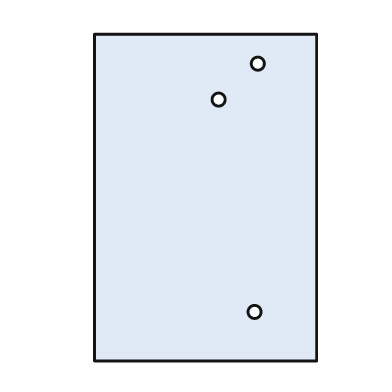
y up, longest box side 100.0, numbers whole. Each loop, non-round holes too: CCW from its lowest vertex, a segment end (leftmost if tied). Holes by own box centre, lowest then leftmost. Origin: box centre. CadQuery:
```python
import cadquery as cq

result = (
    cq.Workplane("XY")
    .moveTo(-34.0, -50.0)
    .lineTo(34.0, -50.0)
    .lineTo(34.0, 50.0)
    .lineTo(-34.0, 50.0)
    .close()
    .moveTo(15.0, -35.0)
    .circle(2.0)
    .moveTo(4.0, 30.0)
    .circle(2.0)
    .moveTo(16.0, 41.0)
    .circle(2.0)
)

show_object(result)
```